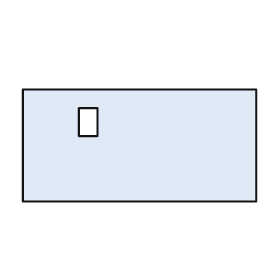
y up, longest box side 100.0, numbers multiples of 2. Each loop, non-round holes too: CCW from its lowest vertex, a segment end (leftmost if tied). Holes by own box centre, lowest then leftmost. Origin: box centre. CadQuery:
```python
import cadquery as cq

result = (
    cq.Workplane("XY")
    .moveTo(-50.0, -24.0)
    .lineTo(50.0, -24.0)
    .lineTo(50.0, 24.0)
    .lineTo(-50.0, 24.0)
    .close()
    .moveTo(-26.0, 4.0)
    .lineTo(-18.0, 4.0)
    .lineTo(-18.0, 16.0)
    .lineTo(-26.0, 16.0)
    .close()
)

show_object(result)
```